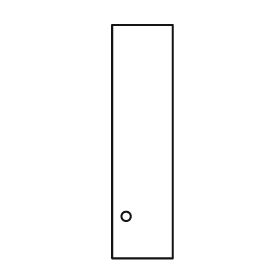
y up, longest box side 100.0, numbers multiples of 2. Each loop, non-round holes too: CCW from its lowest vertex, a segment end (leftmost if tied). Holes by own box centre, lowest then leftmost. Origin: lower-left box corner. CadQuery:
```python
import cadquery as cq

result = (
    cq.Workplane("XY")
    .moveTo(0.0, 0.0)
    .lineTo(26.0, 0.0)
    .lineTo(26.0, 100.0)
    .lineTo(0.0, 100.0)
    .close()
    .moveTo(6.0, 18.0)
    .circle(2.0)
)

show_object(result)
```